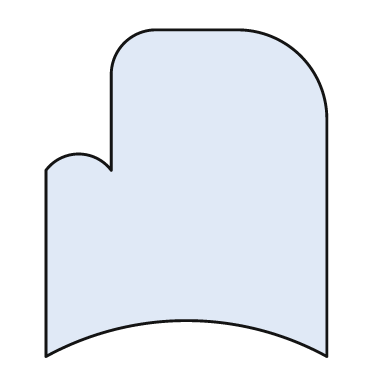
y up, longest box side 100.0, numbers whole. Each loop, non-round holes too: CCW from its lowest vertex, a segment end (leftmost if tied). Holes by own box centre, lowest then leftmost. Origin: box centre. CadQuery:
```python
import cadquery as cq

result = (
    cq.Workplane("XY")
    .moveTo(-43.0, -50.0)
    .threePointArc((0.0, -39.0), (43.0, -50.0))
    .lineTo(43.0, 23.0)
    .threePointArc((35.0, 42.0), (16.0, 50.0))
    .lineTo(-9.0, 50.0)
    .threePointArc((-19.0, 46.0), (-23.0, 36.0))
    .lineTo(-23.0, 7.0)
    .threePointArc((-33.0, 12.0), (-43.0, 7.0))
    .close()
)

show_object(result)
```